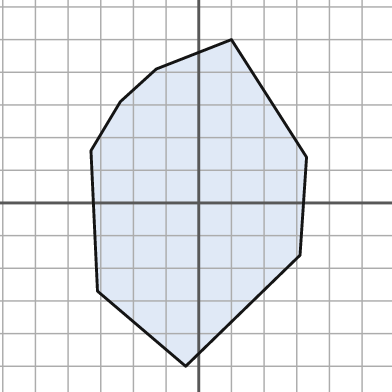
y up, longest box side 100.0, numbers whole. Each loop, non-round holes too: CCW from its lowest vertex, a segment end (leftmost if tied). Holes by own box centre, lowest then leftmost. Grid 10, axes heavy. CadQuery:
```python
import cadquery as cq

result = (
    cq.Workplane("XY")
    .moveTo(-4.0, -50.0)
    .lineTo(31.0, -16.0)
    .lineTo(33.0, 14.0)
    .lineTo(10.0, 50.0)
    .lineTo(-13.0, 41.0)
    .lineTo(-24.0, 31.0)
    .lineTo(-33.0, 16.0)
    .lineTo(-31.0, -27.0)
    .close()
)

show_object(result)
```